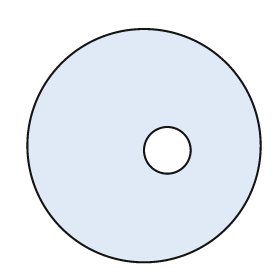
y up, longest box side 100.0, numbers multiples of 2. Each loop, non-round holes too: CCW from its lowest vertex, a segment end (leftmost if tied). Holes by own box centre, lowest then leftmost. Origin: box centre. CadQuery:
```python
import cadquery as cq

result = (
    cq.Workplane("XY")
    .moveTo(0.0, 0.0)
    .circle(50.0)
    .moveTo(10.0, -2.0)
    .circle(10.0)
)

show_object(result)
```